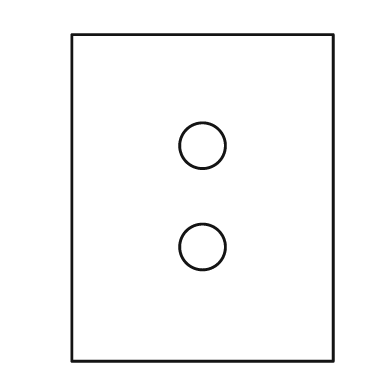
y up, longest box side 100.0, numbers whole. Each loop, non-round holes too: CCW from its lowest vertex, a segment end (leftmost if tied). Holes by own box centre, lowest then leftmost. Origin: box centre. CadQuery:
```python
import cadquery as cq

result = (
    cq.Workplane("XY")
    .moveTo(-40.0, -50.0)
    .lineTo(40.0, -50.0)
    .lineTo(40.0, 50.0)
    .lineTo(-40.0, 50.0)
    .close()
    .moveTo(0.0, -15.0)
    .circle(7.0)
    .moveTo(0.0, 16.0)
    .circle(7.0)
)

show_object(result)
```